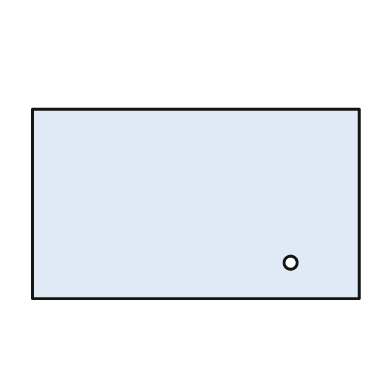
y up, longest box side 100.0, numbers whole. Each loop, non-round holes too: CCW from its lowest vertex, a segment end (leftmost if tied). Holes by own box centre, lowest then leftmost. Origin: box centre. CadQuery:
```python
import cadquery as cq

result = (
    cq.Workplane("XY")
    .moveTo(-50.0, -29.0)
    .lineTo(50.0, -29.0)
    .lineTo(50.0, 29.0)
    .lineTo(-50.0, 29.0)
    .close()
    .moveTo(29.0, -18.0)
    .circle(2.0)
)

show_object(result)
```